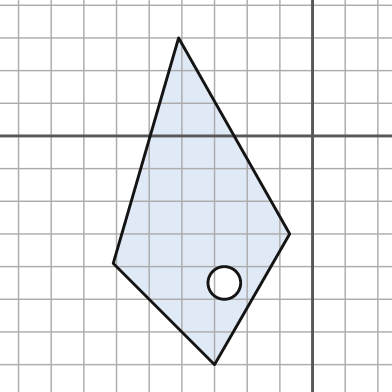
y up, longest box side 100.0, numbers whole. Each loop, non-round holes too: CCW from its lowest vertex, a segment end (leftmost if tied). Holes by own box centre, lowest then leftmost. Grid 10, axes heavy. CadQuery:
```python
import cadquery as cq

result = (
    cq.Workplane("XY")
    .moveTo(-30.0, -70.0)
    .lineTo(-7.0, -30.0)
    .lineTo(-41.0, 30.0)
    .lineTo(-61.0, -39.0)
    .close()
    .moveTo(-27.0, -45.0)
    .circle(5.0)
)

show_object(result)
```